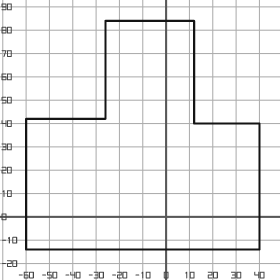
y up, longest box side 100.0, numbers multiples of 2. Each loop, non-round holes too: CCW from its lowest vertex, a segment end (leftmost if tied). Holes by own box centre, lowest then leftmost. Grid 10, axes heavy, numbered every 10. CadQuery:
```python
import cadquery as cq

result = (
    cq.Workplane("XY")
    .moveTo(-60.0, -14.0)
    .lineTo(40.0, -14.0)
    .lineTo(40.0, 40.0)
    .lineTo(12.0, 40.0)
    .lineTo(12.0, 84.0)
    .lineTo(-26.0, 84.0)
    .lineTo(-26.0, 42.0)
    .lineTo(-60.0, 42.0)
    .close()
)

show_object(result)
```